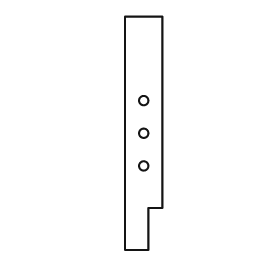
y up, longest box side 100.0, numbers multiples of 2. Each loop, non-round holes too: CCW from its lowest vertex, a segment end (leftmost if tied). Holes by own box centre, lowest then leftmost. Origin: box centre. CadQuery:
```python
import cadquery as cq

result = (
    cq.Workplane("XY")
    .moveTo(-8.0, -50.0)
    .lineTo(2.0, -50.0)
    .lineTo(2.0, -32.0)
    .lineTo(8.0, -32.0)
    .lineTo(8.0, 50.0)
    .lineTo(-8.0, 50.0)
    .close()
    .moveTo(0.0, -14.0)
    .circle(2.0)
    .moveTo(0.0, 0.0)
    .circle(2.0)
    .moveTo(0.0, 14.0)
    .circle(2.0)
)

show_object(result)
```